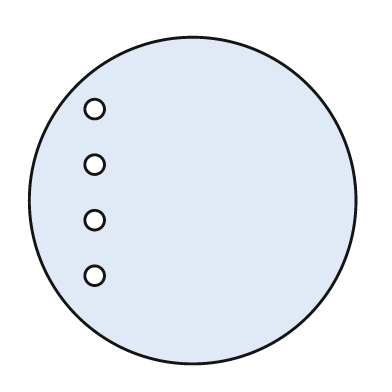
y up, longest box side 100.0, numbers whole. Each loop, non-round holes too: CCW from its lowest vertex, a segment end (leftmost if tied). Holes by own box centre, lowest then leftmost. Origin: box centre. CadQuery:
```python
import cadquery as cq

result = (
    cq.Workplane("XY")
    .moveTo(0.0, 0.0)
    .circle(50.0)
    .moveTo(-30.0, -23.0)
    .circle(3.0)
    .moveTo(-30.0, -6.0)
    .circle(3.0)
    .moveTo(-30.0, 11.0)
    .circle(3.0)
    .moveTo(-30.0, 28.0)
    .circle(3.0)
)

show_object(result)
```